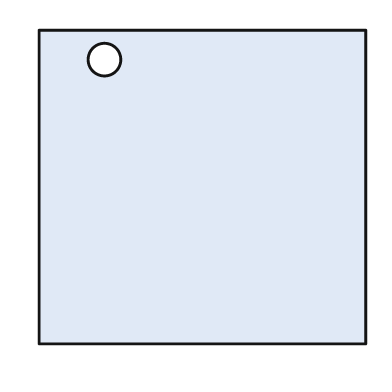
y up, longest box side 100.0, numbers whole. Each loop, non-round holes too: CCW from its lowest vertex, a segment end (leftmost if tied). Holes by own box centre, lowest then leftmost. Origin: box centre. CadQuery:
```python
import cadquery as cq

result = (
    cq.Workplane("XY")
    .moveTo(-50.0, -48.0)
    .lineTo(50.0, -48.0)
    .lineTo(50.0, 48.0)
    .lineTo(-50.0, 48.0)
    .close()
    .moveTo(-30.0, 39.0)
    .circle(5.0)
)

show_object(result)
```